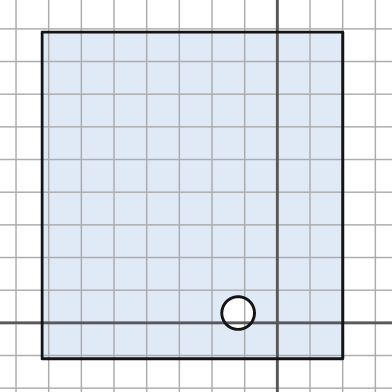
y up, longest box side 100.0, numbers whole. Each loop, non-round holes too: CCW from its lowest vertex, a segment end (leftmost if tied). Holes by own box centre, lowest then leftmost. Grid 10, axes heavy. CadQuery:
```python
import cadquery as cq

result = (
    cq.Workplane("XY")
    .moveTo(-72.0, -11.0)
    .lineTo(20.0, -11.0)
    .lineTo(20.0, 89.0)
    .lineTo(-72.0, 89.0)
    .close()
    .moveTo(-12.0, 3.0)
    .circle(5.0)
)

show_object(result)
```